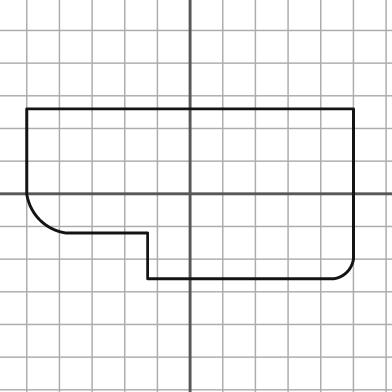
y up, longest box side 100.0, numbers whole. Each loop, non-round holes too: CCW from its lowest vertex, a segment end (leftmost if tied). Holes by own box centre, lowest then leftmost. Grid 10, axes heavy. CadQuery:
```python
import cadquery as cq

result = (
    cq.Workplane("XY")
    .moveTo(-13.0, -26.0)
    .lineTo(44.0, -26.0)
    .threePointArc((48.0, -24.0), (50.0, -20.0))
    .lineTo(50.0, 26.0)
    .lineTo(-50.0, 26.0)
    .lineTo(-50.0, 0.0)
    .threePointArc((-46.0, -8.0), (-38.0, -12.0))
    .lineTo(-13.0, -12.0)
    .close()
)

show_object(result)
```